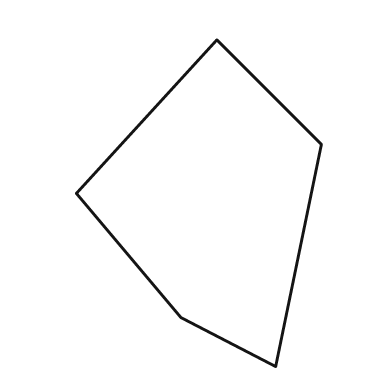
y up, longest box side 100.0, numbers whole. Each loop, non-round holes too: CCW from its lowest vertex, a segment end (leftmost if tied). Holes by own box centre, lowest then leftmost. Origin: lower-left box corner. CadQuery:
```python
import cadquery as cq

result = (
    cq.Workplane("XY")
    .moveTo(61.0, 0.0)
    .lineTo(75.0, 68.0)
    .lineTo(43.0, 100.0)
    .lineTo(0.0, 53.0)
    .lineTo(32.0, 15.0)
    .close()
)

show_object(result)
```